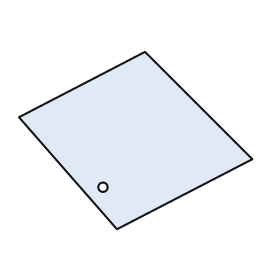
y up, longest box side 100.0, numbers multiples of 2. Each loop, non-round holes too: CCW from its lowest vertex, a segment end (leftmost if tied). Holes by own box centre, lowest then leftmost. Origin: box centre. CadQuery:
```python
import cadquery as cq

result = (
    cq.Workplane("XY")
    .moveTo(-8.0, -38.0)
    .lineTo(50.0, -8.0)
    .lineTo(4.0, 38.0)
    .lineTo(-50.0, 10.0)
    .close()
    .moveTo(-14.0, -20.0)
    .circle(2.0)
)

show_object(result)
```